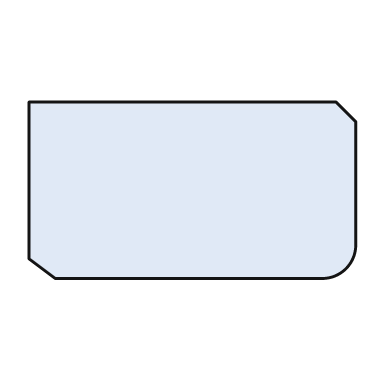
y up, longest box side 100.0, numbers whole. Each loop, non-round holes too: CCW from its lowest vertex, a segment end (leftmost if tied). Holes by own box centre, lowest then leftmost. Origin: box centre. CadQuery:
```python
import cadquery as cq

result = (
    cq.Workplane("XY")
    .moveTo(-42.0, -27.0)
    .lineTo(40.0, -27.0)
    .threePointArc((47.0, -24.0), (50.0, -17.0))
    .lineTo(50.0, 21.0)
    .lineTo(44.0, 27.0)
    .lineTo(-50.0, 27.0)
    .lineTo(-50.0, -21.0)
    .close()
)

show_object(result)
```